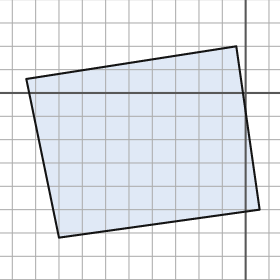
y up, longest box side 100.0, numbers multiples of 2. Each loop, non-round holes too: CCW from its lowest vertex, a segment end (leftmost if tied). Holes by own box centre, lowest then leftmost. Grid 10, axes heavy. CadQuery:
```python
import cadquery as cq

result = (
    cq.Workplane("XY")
    .moveTo(-80.0, -62.0)
    .lineTo(6.0, -50.0)
    .lineTo(-4.0, 20.0)
    .lineTo(-94.0, 6.0)
    .close()
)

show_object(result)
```